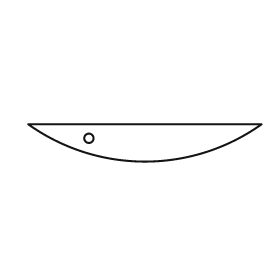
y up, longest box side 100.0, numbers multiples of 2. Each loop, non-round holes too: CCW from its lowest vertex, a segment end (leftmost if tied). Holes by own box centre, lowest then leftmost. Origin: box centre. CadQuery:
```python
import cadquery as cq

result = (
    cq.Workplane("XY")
    .moveTo(-50.0, 8.0)
    .threePointArc((0.0, -8.0), (50.0, 8.0))
    .close()
    .moveTo(-24.0, 2.0)
    .circle(2.0)
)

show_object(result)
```